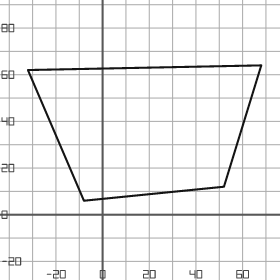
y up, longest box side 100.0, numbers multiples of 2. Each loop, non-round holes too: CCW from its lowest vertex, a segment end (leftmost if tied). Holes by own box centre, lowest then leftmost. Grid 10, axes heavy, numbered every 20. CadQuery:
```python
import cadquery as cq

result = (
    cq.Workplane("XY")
    .moveTo(-8.0, 6.0)
    .lineTo(52.0, 12.0)
    .lineTo(68.0, 64.0)
    .lineTo(-32.0, 62.0)
    .close()
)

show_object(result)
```